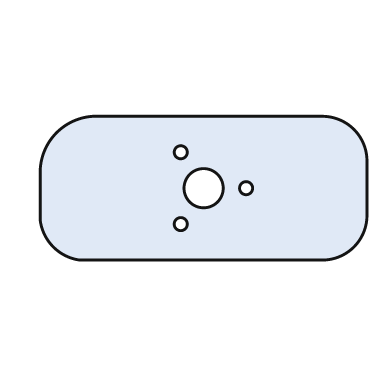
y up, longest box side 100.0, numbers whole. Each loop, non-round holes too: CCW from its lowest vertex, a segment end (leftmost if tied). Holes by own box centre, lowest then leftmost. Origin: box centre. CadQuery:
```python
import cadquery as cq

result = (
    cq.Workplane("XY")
    .moveTo(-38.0, -22.0)
    .lineTo(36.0, -22.0)
    .threePointArc((46.0, -18.0), (50.0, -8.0))
    .lineTo(50.0, 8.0)
    .threePointArc((46.0, 18.0), (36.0, 22.0))
    .lineTo(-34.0, 22.0)
    .threePointArc((-45.0, 17.0), (-50.0, 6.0))
    .lineTo(-50.0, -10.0)
    .threePointArc((-46.0, -18.0), (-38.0, -22.0))
    .close()
    .moveTo(-7.0, -11.0)
    .circle(2.0)
    .moveTo(0.0, 0.0)
    .circle(6.0)
    .moveTo(13.0, 0.0)
    .circle(2.0)
    .moveTo(-7.0, 11.0)
    .circle(2.0)
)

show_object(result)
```